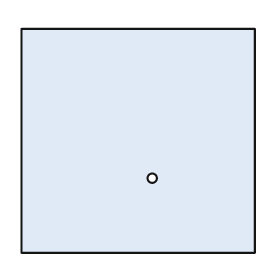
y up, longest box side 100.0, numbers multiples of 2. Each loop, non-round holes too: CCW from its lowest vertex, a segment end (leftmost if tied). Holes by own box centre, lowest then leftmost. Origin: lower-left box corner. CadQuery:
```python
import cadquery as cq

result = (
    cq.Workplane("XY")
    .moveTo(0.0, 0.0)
    .lineTo(100.0, 0.0)
    .lineTo(100.0, 96.0)
    .lineTo(0.0, 96.0)
    .close()
    .moveTo(56.0, 32.0)
    .circle(2.0)
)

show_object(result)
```